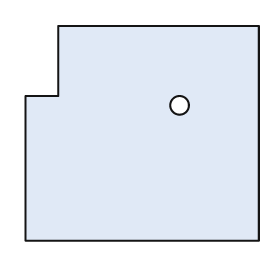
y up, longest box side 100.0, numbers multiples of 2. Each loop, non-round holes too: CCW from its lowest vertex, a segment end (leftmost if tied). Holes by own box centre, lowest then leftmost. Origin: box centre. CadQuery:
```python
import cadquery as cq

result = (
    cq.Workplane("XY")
    .moveTo(-50.0, -46.0)
    .lineTo(50.0, -46.0)
    .lineTo(50.0, 46.0)
    .lineTo(-36.0, 46.0)
    .lineTo(-36.0, 16.0)
    .lineTo(-50.0, 16.0)
    .close()
    .moveTo(16.0, 12.0)
    .circle(4.0)
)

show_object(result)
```